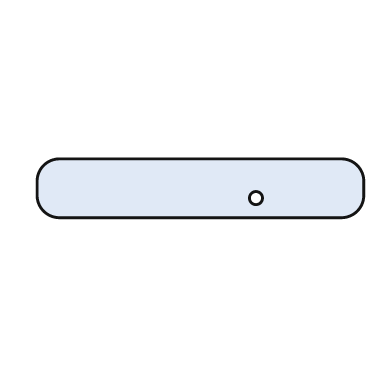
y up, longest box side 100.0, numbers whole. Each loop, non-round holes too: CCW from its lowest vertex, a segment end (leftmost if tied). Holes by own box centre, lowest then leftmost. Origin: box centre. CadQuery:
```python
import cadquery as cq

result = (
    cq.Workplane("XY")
    .moveTo(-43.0, -9.0)
    .lineTo(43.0, -9.0)
    .threePointArc((48.0, -7.0), (50.0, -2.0))
    .lineTo(50.0, 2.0)
    .threePointArc((48.0, 7.0), (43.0, 9.0))
    .lineTo(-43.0, 9.0)
    .threePointArc((-48.0, 7.0), (-50.0, 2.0))
    .lineTo(-50.0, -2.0)
    .threePointArc((-48.0, -7.0), (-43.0, -9.0))
    .close()
    .moveTo(17.0, -3.0)
    .circle(2.0)
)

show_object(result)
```